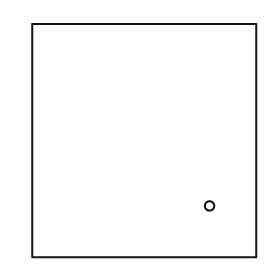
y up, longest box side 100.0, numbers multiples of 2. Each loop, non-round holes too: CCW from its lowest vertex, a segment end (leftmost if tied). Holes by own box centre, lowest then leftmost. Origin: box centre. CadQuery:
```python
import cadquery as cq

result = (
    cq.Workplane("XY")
    .moveTo(-48.0, -50.0)
    .lineTo(48.0, -50.0)
    .lineTo(48.0, 50.0)
    .lineTo(-48.0, 50.0)
    .close()
    .moveTo(28.0, -28.0)
    .circle(2.0)
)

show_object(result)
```